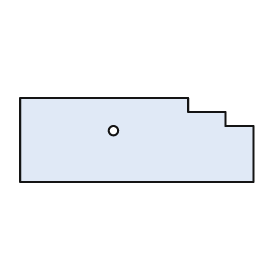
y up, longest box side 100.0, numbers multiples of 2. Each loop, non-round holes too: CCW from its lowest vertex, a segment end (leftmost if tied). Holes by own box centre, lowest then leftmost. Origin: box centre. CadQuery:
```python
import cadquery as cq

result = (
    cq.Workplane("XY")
    .moveTo(-50.0, -18.0)
    .lineTo(50.0, -18.0)
    .lineTo(50.0, 6.0)
    .lineTo(38.0, 6.0)
    .lineTo(38.0, 12.0)
    .lineTo(22.0, 12.0)
    .lineTo(22.0, 18.0)
    .lineTo(-50.0, 18.0)
    .close()
    .moveTo(-10.0, 4.0)
    .circle(2.0)
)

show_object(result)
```